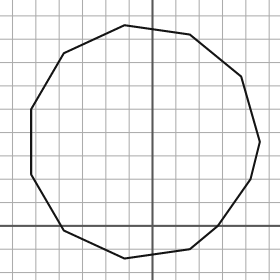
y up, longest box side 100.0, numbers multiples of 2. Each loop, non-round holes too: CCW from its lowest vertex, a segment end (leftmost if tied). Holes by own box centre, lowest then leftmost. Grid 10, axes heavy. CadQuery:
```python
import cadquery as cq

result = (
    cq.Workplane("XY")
    .moveTo(-12.0, -14.0)
    .lineTo(16.0, -10.0)
    .lineTo(28.0, 0.0)
    .lineTo(42.0, 20.0)
    .lineTo(46.0, 36.0)
    .lineTo(38.0, 64.0)
    .lineTo(16.0, 82.0)
    .lineTo(-12.0, 86.0)
    .lineTo(-38.0, 74.0)
    .lineTo(-52.0, 50.0)
    .lineTo(-52.0, 22.0)
    .lineTo(-38.0, -2.0)
    .close()
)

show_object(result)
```